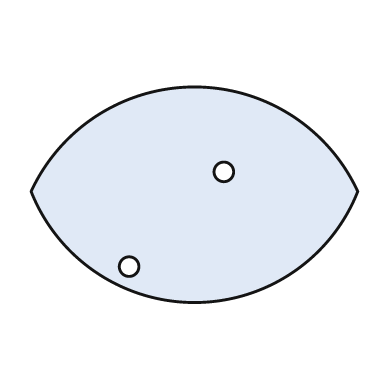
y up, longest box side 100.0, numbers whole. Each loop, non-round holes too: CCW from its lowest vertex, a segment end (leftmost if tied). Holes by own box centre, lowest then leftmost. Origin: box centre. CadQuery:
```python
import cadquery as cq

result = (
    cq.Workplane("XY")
    .moveTo(-50.0, 1.0)
    .threePointArc((0.0, -33.0), (50.0, 1.0))
    .threePointArc((0.0, 33.0), (-50.0, 1.0))
    .close()
    .moveTo(-20.0, -22.0)
    .circle(3.0)
    .moveTo(9.0, 7.0)
    .circle(3.0)
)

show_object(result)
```